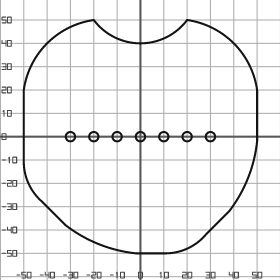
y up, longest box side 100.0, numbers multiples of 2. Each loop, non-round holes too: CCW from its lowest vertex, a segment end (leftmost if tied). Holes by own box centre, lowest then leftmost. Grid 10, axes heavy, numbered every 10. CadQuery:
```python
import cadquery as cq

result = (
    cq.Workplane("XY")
    .moveTo(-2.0, -50.0)
    .lineTo(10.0, -50.0)
    .threePointArc((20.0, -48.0), (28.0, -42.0))
    .lineTo(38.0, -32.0)
    .threePointArc((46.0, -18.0), (50.0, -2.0))
    .lineTo(50.0, 20.0)
    .threePointArc((40.0, 40.0), (20.0, 50.0))
    .threePointArc((0.0, 40.0), (-20.0, 50.0))
    .threePointArc((-40.0, 40.0), (-50.0, 20.0))
    .lineTo(-50.0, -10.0)
    .threePointArc((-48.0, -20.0), (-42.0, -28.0))
    .lineTo(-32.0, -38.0)
    .threePointArc((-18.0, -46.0), (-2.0, -50.0))
    .close()
    .moveTo(-30.0, 0.0)
    .circle(2.0)
    .moveTo(-20.0, 0.0)
    .circle(2.0)
    .moveTo(-10.0, 0.0)
    .circle(2.0)
    .moveTo(0.0, 0.0)
    .circle(2.0)
    .moveTo(10.0, 0.0)
    .circle(2.0)
    .moveTo(20.0, 0.0)
    .circle(2.0)
    .moveTo(30.0, 0.0)
    .circle(2.0)
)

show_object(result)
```